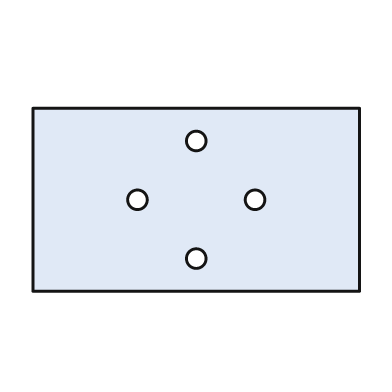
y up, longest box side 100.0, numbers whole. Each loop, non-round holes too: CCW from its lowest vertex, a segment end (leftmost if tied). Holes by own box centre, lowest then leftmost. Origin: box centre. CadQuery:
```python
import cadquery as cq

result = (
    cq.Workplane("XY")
    .moveTo(-50.0, -28.0)
    .lineTo(50.0, -28.0)
    .lineTo(50.0, 28.0)
    .lineTo(-50.0, 28.0)
    .close()
    .moveTo(0.0, -18.0)
    .circle(3.0)
    .moveTo(-18.0, 0.0)
    .circle(3.0)
    .moveTo(18.0, 0.0)
    .circle(3.0)
    .moveTo(0.0, 18.0)
    .circle(3.0)
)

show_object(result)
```